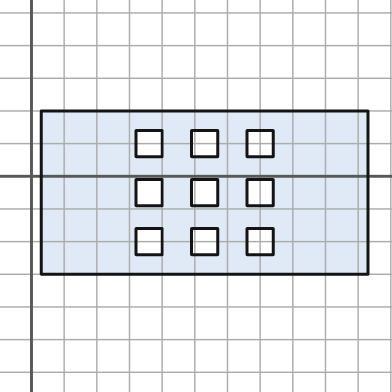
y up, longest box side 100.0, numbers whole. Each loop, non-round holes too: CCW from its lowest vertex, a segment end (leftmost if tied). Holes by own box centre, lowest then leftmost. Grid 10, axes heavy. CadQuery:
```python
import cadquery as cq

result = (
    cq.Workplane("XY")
    .moveTo(3.0, -30.0)
    .lineTo(103.0, -30.0)
    .lineTo(103.0, 20.0)
    .lineTo(3.0, 20.0)
    .close()
    .moveTo(32.0, -24.0)
    .lineTo(40.0, -24.0)
    .lineTo(40.0, -16.0)
    .lineTo(32.0, -16.0)
    .close()
    .moveTo(49.0, -24.0)
    .lineTo(57.0, -24.0)
    .lineTo(57.0, -16.0)
    .lineTo(49.0, -16.0)
    .close()
    .moveTo(66.0, -24.0)
    .lineTo(74.0, -24.0)
    .lineTo(74.0, -16.0)
    .lineTo(66.0, -16.0)
    .close()
    .moveTo(32.0, -9.0)
    .lineTo(40.0, -9.0)
    .lineTo(40.0, -1.0)
    .lineTo(32.0, -1.0)
    .close()
    .moveTo(49.0, -9.0)
    .lineTo(57.0, -9.0)
    .lineTo(57.0, -1.0)
    .lineTo(49.0, -1.0)
    .close()
    .moveTo(66.0, -9.0)
    .lineTo(74.0, -9.0)
    .lineTo(74.0, -1.0)
    .lineTo(66.0, -1.0)
    .close()
    .moveTo(32.0, 6.0)
    .lineTo(40.0, 6.0)
    .lineTo(40.0, 14.0)
    .lineTo(32.0, 14.0)
    .close()
    .moveTo(49.0, 6.0)
    .lineTo(57.0, 6.0)
    .lineTo(57.0, 14.0)
    .lineTo(49.0, 14.0)
    .close()
    .moveTo(66.0, 6.0)
    .lineTo(74.0, 6.0)
    .lineTo(74.0, 14.0)
    .lineTo(66.0, 14.0)
    .close()
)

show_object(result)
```